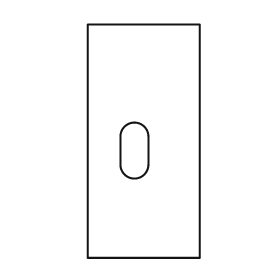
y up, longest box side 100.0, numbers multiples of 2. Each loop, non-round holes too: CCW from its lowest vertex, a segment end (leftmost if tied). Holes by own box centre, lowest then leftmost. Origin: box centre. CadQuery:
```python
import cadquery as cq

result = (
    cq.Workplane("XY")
    .moveTo(-24.0, -50.0)
    .lineTo(24.0, -50.0)
    .lineTo(24.0, 50.0)
    .lineTo(-24.0, 50.0)
    .close()
    .moveTo(-10.0, -10.0)
    .threePointArc((-4.0, -16.0), (2.0, -10.0))
    .lineTo(2.0, 2.0)
    .threePointArc((-4.0, 8.0), (-10.0, 2.0))
    .close()
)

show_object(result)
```